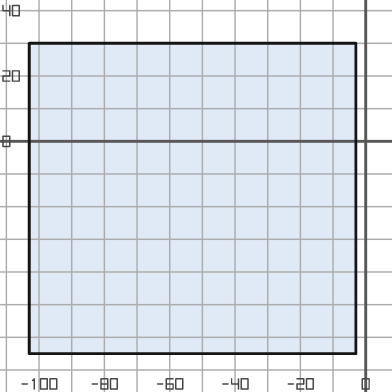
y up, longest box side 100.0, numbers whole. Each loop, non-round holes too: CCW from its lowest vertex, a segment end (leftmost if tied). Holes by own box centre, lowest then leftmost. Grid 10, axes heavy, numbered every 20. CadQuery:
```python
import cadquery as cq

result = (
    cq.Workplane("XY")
    .moveTo(-103.0, -65.0)
    .lineTo(-3.0, -65.0)
    .lineTo(-3.0, 30.0)
    .lineTo(-103.0, 30.0)
    .close()
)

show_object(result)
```